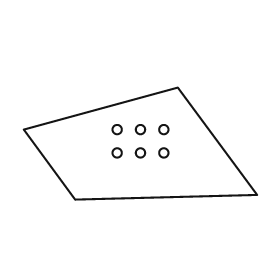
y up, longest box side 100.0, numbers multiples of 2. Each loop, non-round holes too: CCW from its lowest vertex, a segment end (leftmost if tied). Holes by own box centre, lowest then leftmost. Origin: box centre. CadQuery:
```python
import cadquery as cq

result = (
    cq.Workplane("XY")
    .moveTo(-28.0, -24.0)
    .lineTo(50.0, -22.0)
    .lineTo(16.0, 24.0)
    .lineTo(-50.0, 6.0)
    .close()
    .moveTo(-10.0, -4.0)
    .circle(2.0)
    .moveTo(0.0, -4.0)
    .circle(2.0)
    .moveTo(10.0, -4.0)
    .circle(2.0)
    .moveTo(-10.0, 6.0)
    .circle(2.0)
    .moveTo(0.0, 6.0)
    .circle(2.0)
    .moveTo(10.0, 6.0)
    .circle(2.0)
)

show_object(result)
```